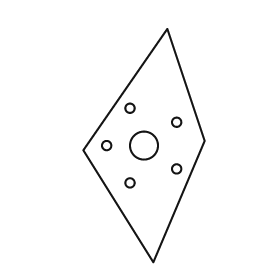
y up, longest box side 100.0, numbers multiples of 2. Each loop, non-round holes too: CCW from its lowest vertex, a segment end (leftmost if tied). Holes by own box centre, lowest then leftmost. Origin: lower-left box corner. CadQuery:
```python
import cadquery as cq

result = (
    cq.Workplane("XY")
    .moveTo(30.0, 0.0)
    .lineTo(52.0, 52.0)
    .lineTo(36.0, 100.0)
    .lineTo(0.0, 48.0)
    .close()
    .moveTo(20.0, 34.0)
    .circle(2.0)
    .moveTo(40.0, 40.0)
    .circle(2.0)
    .moveTo(10.0, 50.0)
    .circle(2.0)
    .moveTo(26.0, 50.0)
    .circle(6.0)
    .moveTo(40.0, 60.0)
    .circle(2.0)
    .moveTo(20.0, 66.0)
    .circle(2.0)
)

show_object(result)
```